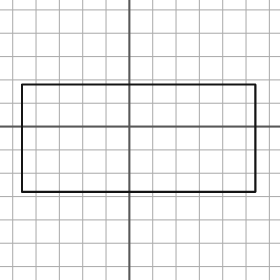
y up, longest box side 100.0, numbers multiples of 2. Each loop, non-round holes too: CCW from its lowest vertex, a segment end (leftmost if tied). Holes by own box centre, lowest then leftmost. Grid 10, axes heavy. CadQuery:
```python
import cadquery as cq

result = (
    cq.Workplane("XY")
    .moveTo(-46.0, -28.0)
    .lineTo(54.0, -28.0)
    .lineTo(54.0, 18.0)
    .lineTo(-46.0, 18.0)
    .close()
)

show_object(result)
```